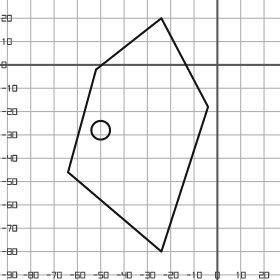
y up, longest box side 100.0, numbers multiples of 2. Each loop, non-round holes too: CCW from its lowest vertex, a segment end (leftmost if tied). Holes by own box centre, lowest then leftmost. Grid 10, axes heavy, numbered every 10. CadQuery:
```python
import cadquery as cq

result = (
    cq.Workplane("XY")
    .moveTo(-24.0, -80.0)
    .lineTo(-4.0, -18.0)
    .lineTo(-24.0, 20.0)
    .lineTo(-52.0, -2.0)
    .lineTo(-64.0, -46.0)
    .close()
    .moveTo(-50.0, -28.0)
    .circle(4.0)
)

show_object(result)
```